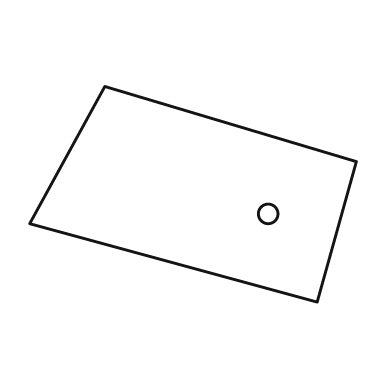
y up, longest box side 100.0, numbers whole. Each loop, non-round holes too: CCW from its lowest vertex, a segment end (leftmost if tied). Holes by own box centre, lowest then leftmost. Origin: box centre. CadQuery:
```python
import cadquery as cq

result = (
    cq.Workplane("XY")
    .moveTo(38.0, -33.0)
    .lineTo(50.0, 10.0)
    .lineTo(-27.0, 33.0)
    .lineTo(-50.0, -9.0)
    .close()
    .moveTo(23.0, -6.0)
    .circle(3.0)
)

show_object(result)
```